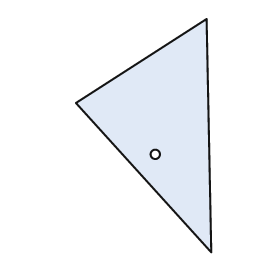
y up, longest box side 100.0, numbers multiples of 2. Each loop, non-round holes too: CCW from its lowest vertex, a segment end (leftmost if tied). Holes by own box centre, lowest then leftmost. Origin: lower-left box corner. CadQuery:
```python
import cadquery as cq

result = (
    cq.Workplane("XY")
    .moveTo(58.0, 0.0)
    .lineTo(56.0, 100.0)
    .lineTo(0.0, 64.0)
    .close()
    .moveTo(34.0, 42.0)
    .circle(2.0)
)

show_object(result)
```